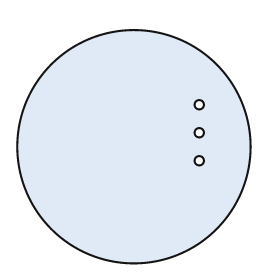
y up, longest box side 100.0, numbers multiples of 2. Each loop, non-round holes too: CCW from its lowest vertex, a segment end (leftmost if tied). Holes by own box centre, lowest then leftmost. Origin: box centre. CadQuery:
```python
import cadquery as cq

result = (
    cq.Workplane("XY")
    .moveTo(0.0, 0.0)
    .circle(50.0)
    .moveTo(28.0, -6.0)
    .circle(2.0)
    .moveTo(28.0, 6.0)
    .circle(2.0)
    .moveTo(28.0, 18.0)
    .circle(2.0)
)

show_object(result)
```